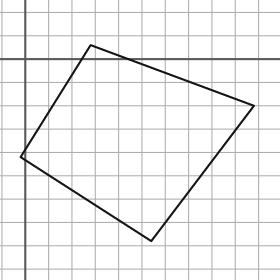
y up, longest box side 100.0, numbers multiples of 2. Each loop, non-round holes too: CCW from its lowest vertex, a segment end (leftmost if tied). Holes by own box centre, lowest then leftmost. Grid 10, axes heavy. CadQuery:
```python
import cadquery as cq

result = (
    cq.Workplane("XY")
    .moveTo(54.0, -78.0)
    .lineTo(98.0, -20.0)
    .lineTo(28.0, 6.0)
    .lineTo(-2.0, -42.0)
    .close()
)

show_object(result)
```